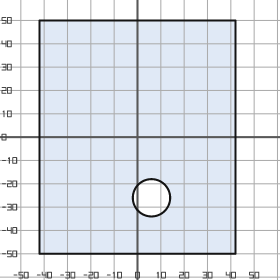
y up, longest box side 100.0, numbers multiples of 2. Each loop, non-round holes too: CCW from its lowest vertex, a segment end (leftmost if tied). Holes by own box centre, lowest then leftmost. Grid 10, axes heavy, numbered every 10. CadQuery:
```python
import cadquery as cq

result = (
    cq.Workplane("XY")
    .moveTo(-42.0, -50.0)
    .lineTo(42.0, -50.0)
    .lineTo(42.0, 50.0)
    .lineTo(-42.0, 50.0)
    .close()
    .moveTo(6.0, -26.0)
    .circle(8.0)
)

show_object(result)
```